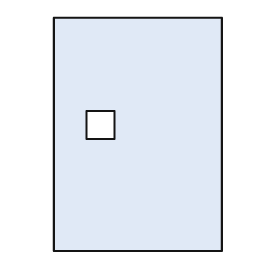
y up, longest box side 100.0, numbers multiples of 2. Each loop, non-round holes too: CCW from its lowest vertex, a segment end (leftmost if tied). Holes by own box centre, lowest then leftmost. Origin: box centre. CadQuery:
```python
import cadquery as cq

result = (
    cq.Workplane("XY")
    .moveTo(-36.0, -50.0)
    .lineTo(36.0, -50.0)
    .lineTo(36.0, 50.0)
    .lineTo(-36.0, 50.0)
    .close()
    .moveTo(-22.0, -2.0)
    .lineTo(-10.0, -2.0)
    .lineTo(-10.0, 10.0)
    .lineTo(-22.0, 10.0)
    .close()
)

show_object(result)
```